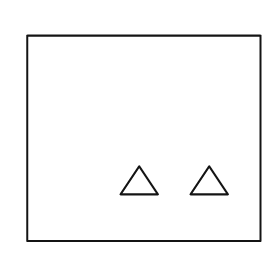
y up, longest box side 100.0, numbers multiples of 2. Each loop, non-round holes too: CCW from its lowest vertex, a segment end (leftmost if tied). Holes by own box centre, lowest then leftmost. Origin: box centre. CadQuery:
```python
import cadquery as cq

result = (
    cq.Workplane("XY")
    .moveTo(-50.0, -44.0)
    .lineTo(50.0, -44.0)
    .lineTo(50.0, 44.0)
    .lineTo(-50.0, 44.0)
    .close()
    .moveTo(-10.0, -24.0)
    .lineTo(6.0, -24.0)
    .lineTo(-2.0, -12.0)
    .close()
    .moveTo(20.0, -24.0)
    .lineTo(36.0, -24.0)
    .lineTo(28.0, -12.0)
    .close()
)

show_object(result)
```